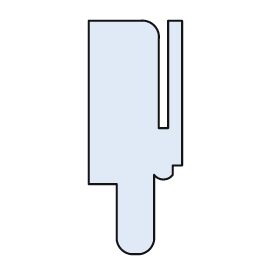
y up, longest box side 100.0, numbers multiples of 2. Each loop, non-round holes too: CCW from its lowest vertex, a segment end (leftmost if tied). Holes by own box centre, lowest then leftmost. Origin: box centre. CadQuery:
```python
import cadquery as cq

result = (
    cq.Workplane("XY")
    .moveTo(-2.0, -50.0)
    .lineTo(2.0, -50.0)
    .threePointArc((6.0, -48.0), (8.0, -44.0))
    .lineTo(8.0, -16.0)
    .threePointArc((12.0, -18.0), (16.0, -16.0))
    .lineTo(16.0, -12.0)
    .lineTo(20.0, -12.0)
    .lineTo(20.0, 50.0)
    .lineTo(14.0, 50.0)
    .lineTo(14.0, 4.0)
    .lineTo(10.0, 4.0)
    .lineTo(10.0, 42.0)
    .threePointArc((8.0, 48.0), (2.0, 50.0))
    .lineTo(-20.0, 50.0)
    .lineTo(-20.0, -20.0)
    .lineTo(-8.0, -20.0)
    .lineTo(-8.0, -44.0)
    .threePointArc((-6.0, -48.0), (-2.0, -50.0))
    .close()
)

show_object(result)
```